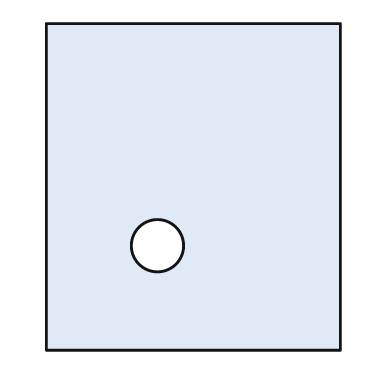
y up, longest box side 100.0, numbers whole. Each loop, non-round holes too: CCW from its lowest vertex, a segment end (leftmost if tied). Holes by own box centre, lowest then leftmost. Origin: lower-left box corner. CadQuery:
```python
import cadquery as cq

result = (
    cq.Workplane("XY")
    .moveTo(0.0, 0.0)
    .lineTo(90.0, 0.0)
    .lineTo(90.0, 100.0)
    .lineTo(0.0, 100.0)
    .close()
    .moveTo(34.0, 32.0)
    .circle(8.0)
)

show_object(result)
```